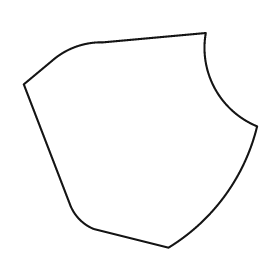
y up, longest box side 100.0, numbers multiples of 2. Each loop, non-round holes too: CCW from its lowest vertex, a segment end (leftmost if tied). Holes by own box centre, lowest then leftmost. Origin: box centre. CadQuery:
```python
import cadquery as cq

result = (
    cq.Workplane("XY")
    .moveTo(12.0, -46.0)
    .threePointArc((36.0, -24.0), (50.0, 6.0))
    .threePointArc((32.0, 22.0), (28.0, 46.0))
    .lineTo(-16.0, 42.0)
    .threePointArc((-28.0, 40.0), (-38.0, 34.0))
    .lineTo(-50.0, 24.0)
    .lineTo(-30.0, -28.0)
    .threePointArc((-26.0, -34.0), (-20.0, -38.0))
    .close()
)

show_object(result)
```